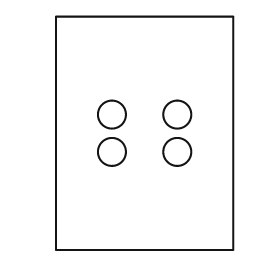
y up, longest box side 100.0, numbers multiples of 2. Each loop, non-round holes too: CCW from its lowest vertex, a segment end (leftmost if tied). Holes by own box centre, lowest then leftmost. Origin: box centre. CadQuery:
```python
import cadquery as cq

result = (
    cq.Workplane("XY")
    .moveTo(-38.0, -50.0)
    .lineTo(38.0, -50.0)
    .lineTo(38.0, 50.0)
    .lineTo(-38.0, 50.0)
    .close()
    .moveTo(-14.0, -8.0)
    .circle(6.0)
    .moveTo(14.0, -8.0)
    .circle(6.0)
    .moveTo(-14.0, 8.0)
    .circle(6.0)
    .moveTo(14.0, 8.0)
    .circle(6.0)
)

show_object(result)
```